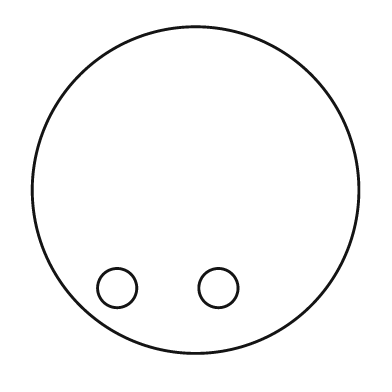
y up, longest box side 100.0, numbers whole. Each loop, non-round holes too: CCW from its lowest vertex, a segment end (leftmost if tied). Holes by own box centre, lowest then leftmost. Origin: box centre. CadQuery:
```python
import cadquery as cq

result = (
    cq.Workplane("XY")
    .moveTo(0.0, 0.0)
    .circle(50.0)
    .moveTo(-24.0, -30.0)
    .circle(6.0)
    .moveTo(7.0, -30.0)
    .circle(6.0)
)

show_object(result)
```